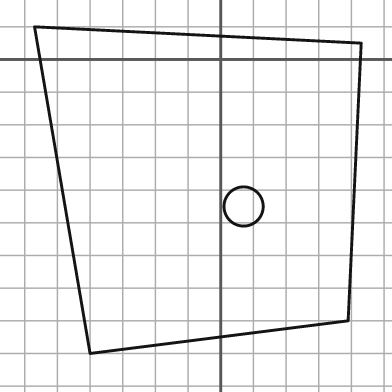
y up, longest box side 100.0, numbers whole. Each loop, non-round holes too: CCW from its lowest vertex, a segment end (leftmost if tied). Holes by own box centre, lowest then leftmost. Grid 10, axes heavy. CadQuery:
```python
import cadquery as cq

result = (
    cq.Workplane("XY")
    .moveTo(-40.0, -90.0)
    .lineTo(39.0, -80.0)
    .lineTo(43.0, 5.0)
    .lineTo(-57.0, 10.0)
    .close()
    .moveTo(7.0, -45.0)
    .circle(6.0)
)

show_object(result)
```